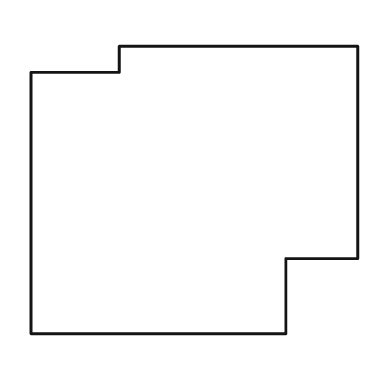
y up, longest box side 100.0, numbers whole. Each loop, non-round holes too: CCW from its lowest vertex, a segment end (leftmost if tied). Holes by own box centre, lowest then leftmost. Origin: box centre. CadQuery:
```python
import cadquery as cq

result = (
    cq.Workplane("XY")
    .moveTo(-50.0, -44.0)
    .lineTo(28.0, -44.0)
    .lineTo(28.0, -21.0)
    .lineTo(50.0, -21.0)
    .lineTo(50.0, 44.0)
    .lineTo(-23.0, 44.0)
    .lineTo(-23.0, 36.0)
    .lineTo(-50.0, 36.0)
    .close()
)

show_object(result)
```